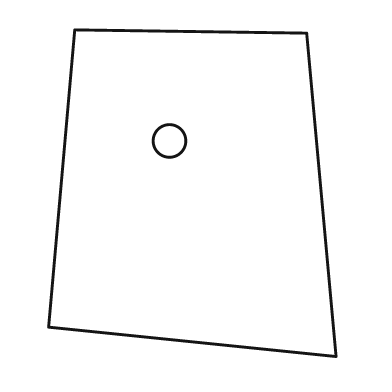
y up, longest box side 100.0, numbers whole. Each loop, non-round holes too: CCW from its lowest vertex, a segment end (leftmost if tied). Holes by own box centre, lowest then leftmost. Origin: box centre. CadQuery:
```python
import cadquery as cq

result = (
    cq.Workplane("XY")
    .moveTo(44.0, -50.0)
    .lineTo(35.0, 49.0)
    .lineTo(-36.0, 50.0)
    .lineTo(-44.0, -41.0)
    .close()
    .moveTo(-7.0, 16.0)
    .circle(5.0)
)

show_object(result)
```